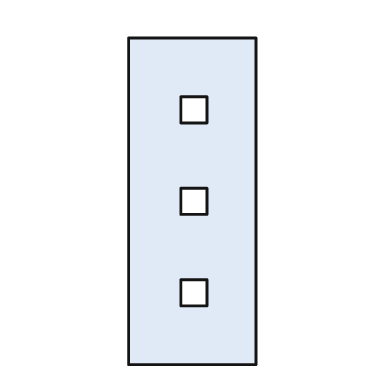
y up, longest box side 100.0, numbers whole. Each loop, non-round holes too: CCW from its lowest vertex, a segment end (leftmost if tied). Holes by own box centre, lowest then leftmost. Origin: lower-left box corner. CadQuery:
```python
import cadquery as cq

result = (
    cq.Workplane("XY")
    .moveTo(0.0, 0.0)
    .lineTo(39.0, 0.0)
    .lineTo(39.0, 100.0)
    .lineTo(0.0, 100.0)
    .close()
    .moveTo(16.0, 18.0)
    .lineTo(24.0, 18.0)
    .lineTo(24.0, 26.0)
    .lineTo(16.0, 26.0)
    .close()
    .moveTo(16.0, 46.0)
    .lineTo(24.0, 46.0)
    .lineTo(24.0, 54.0)
    .lineTo(16.0, 54.0)
    .close()
    .moveTo(16.0, 74.0)
    .lineTo(24.0, 74.0)
    .lineTo(24.0, 82.0)
    .lineTo(16.0, 82.0)
    .close()
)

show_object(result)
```